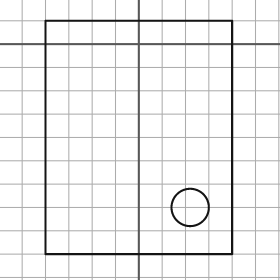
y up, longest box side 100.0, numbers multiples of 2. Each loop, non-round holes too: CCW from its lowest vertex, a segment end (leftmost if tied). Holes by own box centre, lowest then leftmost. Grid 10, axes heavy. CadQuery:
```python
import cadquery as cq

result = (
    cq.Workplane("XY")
    .moveTo(-40.0, -90.0)
    .lineTo(40.0, -90.0)
    .lineTo(40.0, 10.0)
    .lineTo(-40.0, 10.0)
    .close()
    .moveTo(22.0, -70.0)
    .circle(8.0)
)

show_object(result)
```